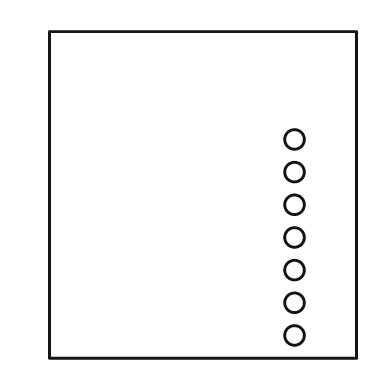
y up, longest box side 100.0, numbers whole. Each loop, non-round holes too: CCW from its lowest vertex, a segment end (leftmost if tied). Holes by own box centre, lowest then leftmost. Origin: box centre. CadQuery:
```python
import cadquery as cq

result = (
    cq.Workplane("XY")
    .moveTo(-47.0, -50.0)
    .lineTo(47.0, -50.0)
    .lineTo(47.0, 50.0)
    .lineTo(-47.0, 50.0)
    .close()
    .moveTo(28.0, -43.0)
    .circle(3.0)
    .moveTo(28.0, -33.0)
    .circle(3.0)
    .moveTo(28.0, -23.0)
    .circle(3.0)
    .moveTo(28.0, -13.0)
    .circle(3.0)
    .moveTo(28.0, -3.0)
    .circle(3.0)
    .moveTo(28.0, 7.0)
    .circle(3.0)
    .moveTo(28.0, 17.0)
    .circle(3.0)
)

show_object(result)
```